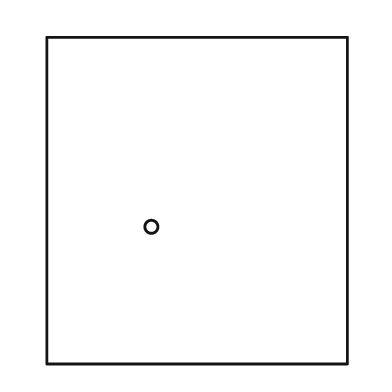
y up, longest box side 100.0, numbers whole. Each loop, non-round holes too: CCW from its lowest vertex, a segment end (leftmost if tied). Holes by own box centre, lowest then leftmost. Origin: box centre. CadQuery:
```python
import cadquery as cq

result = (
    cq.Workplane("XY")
    .moveTo(-46.0, -50.0)
    .lineTo(46.0, -50.0)
    .lineTo(46.0, 50.0)
    .lineTo(-46.0, 50.0)
    .close()
    .moveTo(-14.0, -8.0)
    .circle(2.0)
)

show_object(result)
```